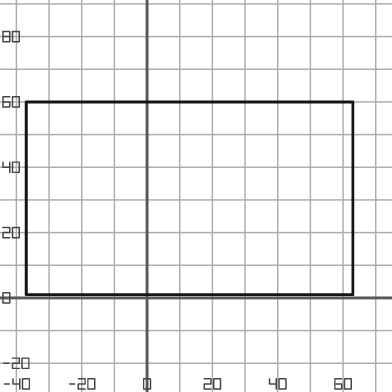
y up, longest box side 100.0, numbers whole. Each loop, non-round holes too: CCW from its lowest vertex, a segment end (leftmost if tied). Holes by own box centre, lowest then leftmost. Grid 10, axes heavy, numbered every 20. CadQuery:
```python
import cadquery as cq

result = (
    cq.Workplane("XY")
    .moveTo(-37.0, 1.0)
    .lineTo(63.0, 1.0)
    .lineTo(63.0, 60.0)
    .lineTo(-37.0, 60.0)
    .close()
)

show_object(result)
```